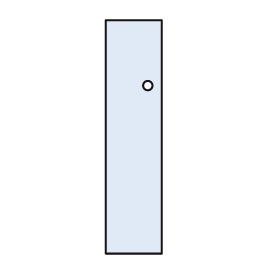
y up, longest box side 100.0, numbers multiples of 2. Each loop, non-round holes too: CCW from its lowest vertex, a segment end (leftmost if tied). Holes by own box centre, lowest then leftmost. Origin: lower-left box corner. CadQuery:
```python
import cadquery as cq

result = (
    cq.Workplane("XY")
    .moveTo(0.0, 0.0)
    .lineTo(24.0, 0.0)
    .lineTo(24.0, 100.0)
    .lineTo(0.0, 100.0)
    .close()
    .moveTo(18.0, 72.0)
    .circle(2.0)
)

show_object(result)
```